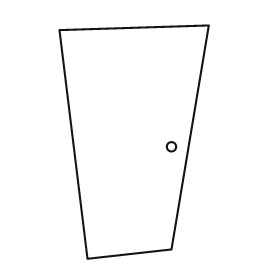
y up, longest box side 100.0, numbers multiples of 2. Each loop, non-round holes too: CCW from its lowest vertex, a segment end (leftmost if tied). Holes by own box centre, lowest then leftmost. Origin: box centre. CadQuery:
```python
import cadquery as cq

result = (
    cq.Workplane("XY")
    .moveTo(-20.0, -50.0)
    .lineTo(16.0, -46.0)
    .lineTo(32.0, 50.0)
    .lineTo(-32.0, 48.0)
    .close()
    .moveTo(16.0, -2.0)
    .circle(2.0)
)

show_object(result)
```